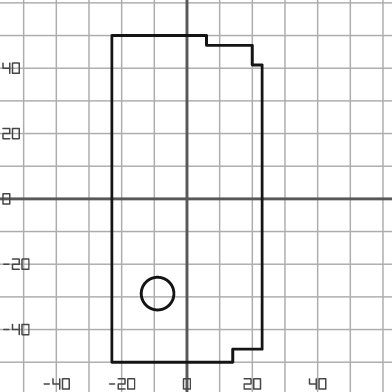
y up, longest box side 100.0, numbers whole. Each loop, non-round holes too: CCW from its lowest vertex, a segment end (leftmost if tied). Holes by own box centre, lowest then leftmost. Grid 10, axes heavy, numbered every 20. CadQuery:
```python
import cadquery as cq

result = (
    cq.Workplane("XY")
    .moveTo(-23.0, -50.0)
    .lineTo(14.0, -50.0)
    .lineTo(14.0, -46.0)
    .lineTo(23.0, -46.0)
    .lineTo(23.0, 41.0)
    .lineTo(20.0, 41.0)
    .lineTo(20.0, 47.0)
    .lineTo(6.0, 47.0)
    .lineTo(6.0, 50.0)
    .lineTo(-23.0, 50.0)
    .close()
    .moveTo(-9.0, -29.0)
    .circle(5.0)
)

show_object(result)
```